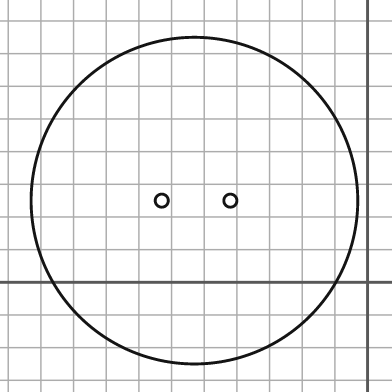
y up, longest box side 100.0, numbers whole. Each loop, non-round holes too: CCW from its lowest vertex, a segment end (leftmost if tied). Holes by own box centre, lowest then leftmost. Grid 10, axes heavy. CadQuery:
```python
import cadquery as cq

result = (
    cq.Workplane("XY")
    .moveTo(-53.0, 25.0)
    .circle(50.0)
    .moveTo(-63.0, 25.0)
    .circle(2.0)
    .moveTo(-42.0, 25.0)
    .circle(2.0)
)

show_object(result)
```